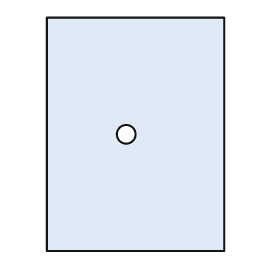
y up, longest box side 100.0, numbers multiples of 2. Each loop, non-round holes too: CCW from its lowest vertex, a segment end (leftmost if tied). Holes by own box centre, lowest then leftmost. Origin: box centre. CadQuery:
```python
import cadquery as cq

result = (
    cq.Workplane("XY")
    .moveTo(-38.0, -50.0)
    .lineTo(38.0, -50.0)
    .lineTo(38.0, 50.0)
    .lineTo(-38.0, 50.0)
    .close()
    .moveTo(-4.0, 0.0)
    .circle(4.0)
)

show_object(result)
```